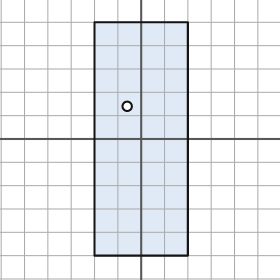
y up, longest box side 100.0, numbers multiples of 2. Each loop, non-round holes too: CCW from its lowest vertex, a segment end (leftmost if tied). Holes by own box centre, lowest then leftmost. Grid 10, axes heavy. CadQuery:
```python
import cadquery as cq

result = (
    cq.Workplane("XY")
    .moveTo(-20.0, -50.0)
    .lineTo(20.0, -50.0)
    .lineTo(20.0, 50.0)
    .lineTo(-20.0, 50.0)
    .close()
    .moveTo(-6.0, 14.0)
    .circle(2.0)
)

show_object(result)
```